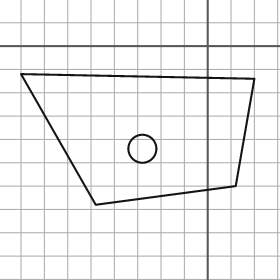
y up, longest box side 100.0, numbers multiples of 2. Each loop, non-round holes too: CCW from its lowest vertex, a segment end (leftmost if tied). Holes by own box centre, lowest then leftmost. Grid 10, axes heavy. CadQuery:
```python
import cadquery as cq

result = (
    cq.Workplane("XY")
    .moveTo(-48.0, -68.0)
    .lineTo(12.0, -60.0)
    .lineTo(20.0, -14.0)
    .lineTo(-80.0, -12.0)
    .close()
    .moveTo(-28.0, -44.0)
    .circle(6.0)
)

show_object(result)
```